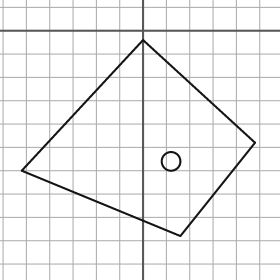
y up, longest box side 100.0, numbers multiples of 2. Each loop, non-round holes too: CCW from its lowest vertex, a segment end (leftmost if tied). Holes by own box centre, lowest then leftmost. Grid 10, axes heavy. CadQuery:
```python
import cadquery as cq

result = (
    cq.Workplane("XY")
    .moveTo(16.0, -88.0)
    .lineTo(48.0, -48.0)
    .lineTo(0.0, -4.0)
    .lineTo(-52.0, -60.0)
    .close()
    .moveTo(12.0, -56.0)
    .circle(4.0)
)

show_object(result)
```